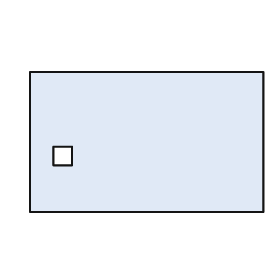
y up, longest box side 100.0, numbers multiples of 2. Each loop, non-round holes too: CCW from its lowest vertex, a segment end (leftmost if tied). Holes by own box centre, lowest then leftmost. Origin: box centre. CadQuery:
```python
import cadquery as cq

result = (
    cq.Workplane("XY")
    .moveTo(-50.0, -30.0)
    .lineTo(50.0, -30.0)
    .lineTo(50.0, 30.0)
    .lineTo(-50.0, 30.0)
    .close()
    .moveTo(-40.0, -10.0)
    .lineTo(-32.0, -10.0)
    .lineTo(-32.0, -2.0)
    .lineTo(-40.0, -2.0)
    .close()
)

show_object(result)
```